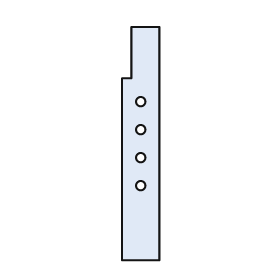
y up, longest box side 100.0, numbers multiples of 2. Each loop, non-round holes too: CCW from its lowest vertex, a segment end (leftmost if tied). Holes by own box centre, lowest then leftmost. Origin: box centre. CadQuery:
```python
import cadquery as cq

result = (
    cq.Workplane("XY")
    .moveTo(-8.0, -50.0)
    .lineTo(8.0, -50.0)
    .lineTo(8.0, 50.0)
    .lineTo(-4.0, 50.0)
    .lineTo(-4.0, 28.0)
    .lineTo(-8.0, 28.0)
    .close()
    .moveTo(0.0, -18.0)
    .circle(2.0)
    .moveTo(0.0, -6.0)
    .circle(2.0)
    .moveTo(0.0, 6.0)
    .circle(2.0)
    .moveTo(0.0, 18.0)
    .circle(2.0)
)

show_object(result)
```